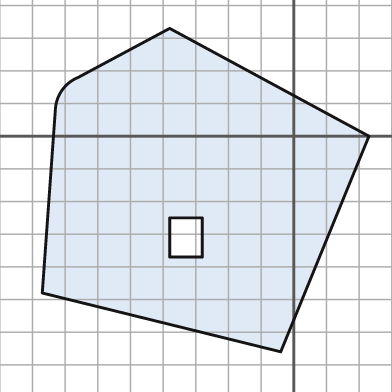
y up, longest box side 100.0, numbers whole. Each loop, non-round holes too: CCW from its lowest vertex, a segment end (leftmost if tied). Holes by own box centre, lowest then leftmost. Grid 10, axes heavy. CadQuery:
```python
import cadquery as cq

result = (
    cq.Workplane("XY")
    .moveTo(-4.0, -66.0)
    .lineTo(23.0, 0.0)
    .lineTo(-38.0, 33.0)
    .lineTo(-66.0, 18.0)
    .threePointArc((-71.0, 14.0), (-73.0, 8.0))
    .lineTo(-77.0, -48.0)
    .close()
    .moveTo(-38.0, -37.0)
    .lineTo(-28.0, -37.0)
    .lineTo(-28.0, -25.0)
    .lineTo(-38.0, -25.0)
    .close()
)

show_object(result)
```